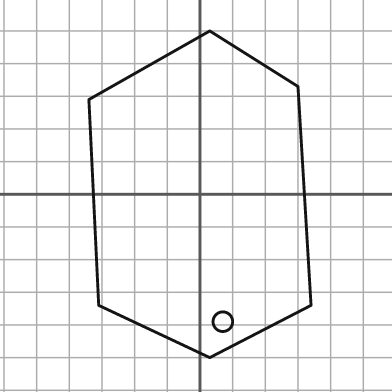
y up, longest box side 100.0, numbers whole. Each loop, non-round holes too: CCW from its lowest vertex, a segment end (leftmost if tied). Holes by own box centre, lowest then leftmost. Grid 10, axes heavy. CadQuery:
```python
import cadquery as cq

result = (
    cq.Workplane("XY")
    .moveTo(3.0, -50.0)
    .lineTo(34.0, -34.0)
    .lineTo(30.0, 33.0)
    .lineTo(3.0, 50.0)
    .lineTo(-34.0, 29.0)
    .lineTo(-31.0, -34.0)
    .close()
    .moveTo(7.0, -39.0)
    .circle(3.0)
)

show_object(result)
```